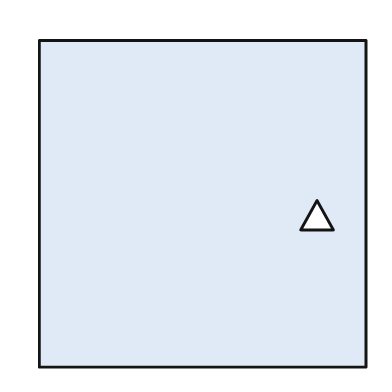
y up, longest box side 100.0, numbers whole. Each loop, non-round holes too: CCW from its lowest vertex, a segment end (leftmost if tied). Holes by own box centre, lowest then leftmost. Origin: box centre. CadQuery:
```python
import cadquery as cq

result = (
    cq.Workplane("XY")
    .moveTo(-50.0, -50.0)
    .lineTo(50.0, -50.0)
    .lineTo(50.0, 50.0)
    .lineTo(-50.0, 50.0)
    .close()
    .moveTo(30.0, -8.0)
    .lineTo(40.0, -8.0)
    .lineTo(35.0, 1.0)
    .close()
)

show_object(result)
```